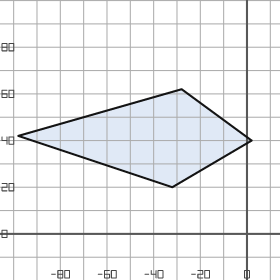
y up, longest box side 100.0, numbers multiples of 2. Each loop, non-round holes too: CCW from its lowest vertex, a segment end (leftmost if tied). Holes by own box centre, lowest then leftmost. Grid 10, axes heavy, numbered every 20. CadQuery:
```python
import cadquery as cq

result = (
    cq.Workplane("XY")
    .moveTo(-32.0, 20.0)
    .lineTo(2.0, 40.0)
    .lineTo(-28.0, 62.0)
    .lineTo(-98.0, 42.0)
    .close()
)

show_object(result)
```